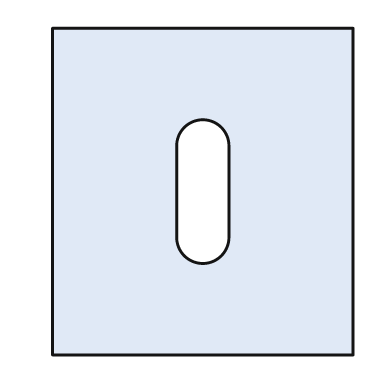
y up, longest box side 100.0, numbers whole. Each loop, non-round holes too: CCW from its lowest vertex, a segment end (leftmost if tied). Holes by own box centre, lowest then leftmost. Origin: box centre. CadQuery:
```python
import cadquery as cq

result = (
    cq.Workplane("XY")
    .moveTo(-46.0, -50.0)
    .lineTo(46.0, -50.0)
    .lineTo(46.0, 50.0)
    .lineTo(-46.0, 50.0)
    .close()
    .moveTo(-8.0, -14.0)
    .threePointArc((0.0, -22.0), (8.0, -14.0))
    .lineTo(8.0, 14.0)
    .threePointArc((0.0, 22.0), (-8.0, 14.0))
    .close()
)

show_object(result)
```